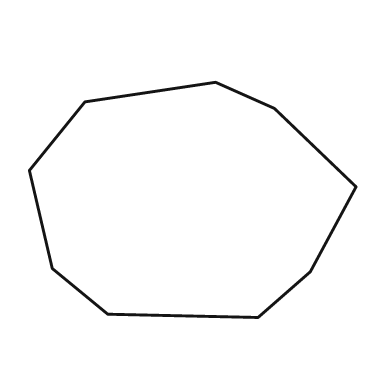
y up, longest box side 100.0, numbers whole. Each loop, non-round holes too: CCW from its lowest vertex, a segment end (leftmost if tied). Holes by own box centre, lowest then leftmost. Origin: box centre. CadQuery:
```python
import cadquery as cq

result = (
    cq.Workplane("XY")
    .moveTo(20.0, -36.0)
    .lineTo(36.0, -22.0)
    .lineTo(50.0, 4.0)
    .lineTo(25.0, 28.0)
    .lineTo(7.0, 36.0)
    .lineTo(-33.0, 30.0)
    .lineTo(-50.0, 9.0)
    .lineTo(-43.0, -21.0)
    .lineTo(-26.0, -35.0)
    .close()
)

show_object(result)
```